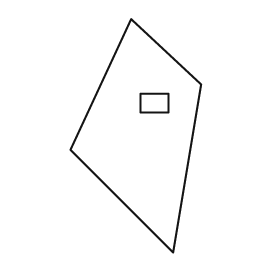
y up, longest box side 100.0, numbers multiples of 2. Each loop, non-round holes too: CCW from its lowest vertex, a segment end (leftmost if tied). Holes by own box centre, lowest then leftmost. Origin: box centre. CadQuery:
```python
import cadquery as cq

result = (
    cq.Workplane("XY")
    .moveTo(16.0, -50.0)
    .lineTo(28.0, 22.0)
    .lineTo(-2.0, 50.0)
    .lineTo(-28.0, -6.0)
    .close()
    .moveTo(2.0, 10.0)
    .lineTo(14.0, 10.0)
    .lineTo(14.0, 18.0)
    .lineTo(2.0, 18.0)
    .close()
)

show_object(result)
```